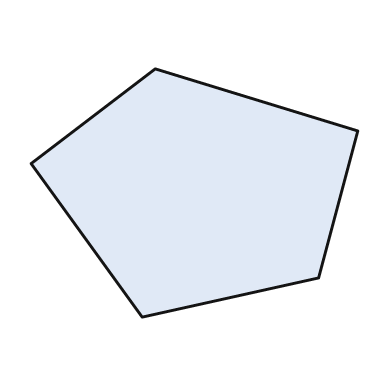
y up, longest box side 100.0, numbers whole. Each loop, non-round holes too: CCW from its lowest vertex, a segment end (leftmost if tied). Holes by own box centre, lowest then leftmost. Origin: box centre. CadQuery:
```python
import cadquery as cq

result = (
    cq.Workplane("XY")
    .moveTo(-16.0, -38.0)
    .lineTo(38.0, -26.0)
    .lineTo(50.0, 19.0)
    .lineTo(-12.0, 38.0)
    .lineTo(-50.0, 9.0)
    .close()
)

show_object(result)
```